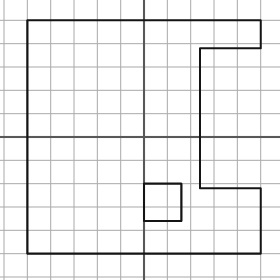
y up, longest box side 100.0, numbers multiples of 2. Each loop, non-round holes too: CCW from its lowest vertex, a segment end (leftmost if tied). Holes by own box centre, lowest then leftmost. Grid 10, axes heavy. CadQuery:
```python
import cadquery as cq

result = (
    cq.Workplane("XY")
    .moveTo(-50.0, -50.0)
    .lineTo(50.0, -50.0)
    .lineTo(50.0, -22.0)
    .lineTo(24.0, -22.0)
    .lineTo(24.0, 38.0)
    .lineTo(50.0, 38.0)
    .lineTo(50.0, 50.0)
    .lineTo(-50.0, 50.0)
    .close()
    .moveTo(0.0, -36.0)
    .lineTo(16.0, -36.0)
    .lineTo(16.0, -20.0)
    .lineTo(0.0, -20.0)
    .close()
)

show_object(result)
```